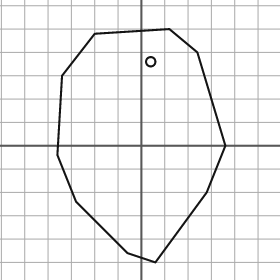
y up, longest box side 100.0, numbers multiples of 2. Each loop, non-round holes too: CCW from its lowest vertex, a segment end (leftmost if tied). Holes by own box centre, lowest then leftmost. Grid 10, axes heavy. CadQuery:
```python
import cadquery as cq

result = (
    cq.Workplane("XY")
    .moveTo(6.0, -50.0)
    .lineTo(28.0, -20.0)
    .lineTo(36.0, 0.0)
    .lineTo(24.0, 40.0)
    .lineTo(12.0, 50.0)
    .lineTo(-20.0, 48.0)
    .lineTo(-34.0, 30.0)
    .lineTo(-36.0, -4.0)
    .lineTo(-28.0, -24.0)
    .lineTo(-6.0, -46.0)
    .close()
    .moveTo(4.0, 36.0)
    .circle(2.0)
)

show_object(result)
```